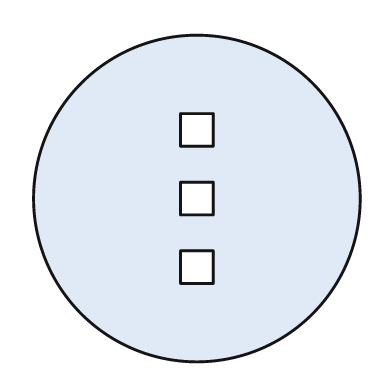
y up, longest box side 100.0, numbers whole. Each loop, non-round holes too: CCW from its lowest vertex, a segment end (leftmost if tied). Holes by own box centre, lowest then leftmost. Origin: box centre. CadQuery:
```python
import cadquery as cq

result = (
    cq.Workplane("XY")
    .moveTo(0.0, 0.0)
    .circle(50.0)
    .moveTo(-5.0, -26.0)
    .lineTo(5.0, -26.0)
    .lineTo(5.0, -16.0)
    .lineTo(-5.0, -16.0)
    .close()
    .moveTo(-5.0, -5.0)
    .lineTo(5.0, -5.0)
    .lineTo(5.0, 5.0)
    .lineTo(-5.0, 5.0)
    .close()
    .moveTo(-5.0, 16.0)
    .lineTo(5.0, 16.0)
    .lineTo(5.0, 26.0)
    .lineTo(-5.0, 26.0)
    .close()
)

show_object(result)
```